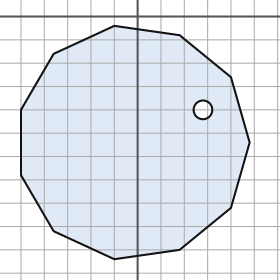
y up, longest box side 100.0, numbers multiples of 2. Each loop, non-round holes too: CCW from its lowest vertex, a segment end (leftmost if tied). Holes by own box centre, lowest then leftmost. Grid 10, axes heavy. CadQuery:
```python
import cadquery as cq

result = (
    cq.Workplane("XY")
    .moveTo(-10.0, -104.0)
    .lineTo(18.0, -100.0)
    .lineTo(40.0, -82.0)
    .lineTo(48.0, -54.0)
    .lineTo(40.0, -26.0)
    .lineTo(18.0, -8.0)
    .lineTo(-10.0, -4.0)
    .lineTo(-36.0, -16.0)
    .lineTo(-50.0, -40.0)
    .lineTo(-50.0, -68.0)
    .lineTo(-36.0, -92.0)
    .close()
    .moveTo(28.0, -40.0)
    .circle(4.0)
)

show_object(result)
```